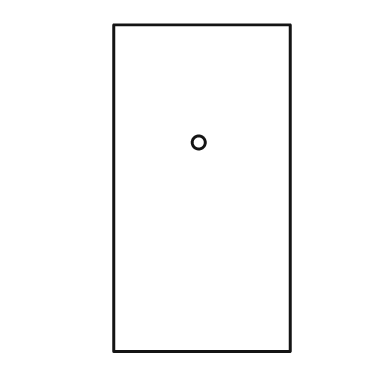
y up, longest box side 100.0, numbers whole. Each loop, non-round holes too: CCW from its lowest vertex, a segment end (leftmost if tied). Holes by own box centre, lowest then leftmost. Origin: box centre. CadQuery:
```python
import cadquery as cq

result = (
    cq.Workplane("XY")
    .moveTo(-27.0, -50.0)
    .lineTo(27.0, -50.0)
    .lineTo(27.0, 50.0)
    .lineTo(-27.0, 50.0)
    .close()
    .moveTo(-1.0, 14.0)
    .circle(2.0)
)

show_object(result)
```